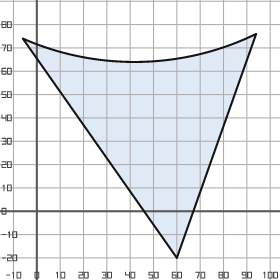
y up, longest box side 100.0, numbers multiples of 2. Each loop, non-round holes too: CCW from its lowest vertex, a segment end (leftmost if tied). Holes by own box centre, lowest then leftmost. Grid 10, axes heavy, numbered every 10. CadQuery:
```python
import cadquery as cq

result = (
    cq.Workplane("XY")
    .moveTo(60.0, -20.0)
    .lineTo(94.0, 76.0)
    .threePointArc((44.0, 64.0), (-6.0, 74.0))
    .close()
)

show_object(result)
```